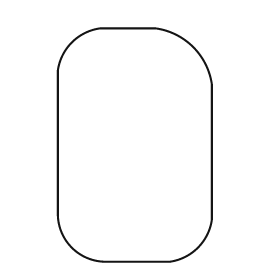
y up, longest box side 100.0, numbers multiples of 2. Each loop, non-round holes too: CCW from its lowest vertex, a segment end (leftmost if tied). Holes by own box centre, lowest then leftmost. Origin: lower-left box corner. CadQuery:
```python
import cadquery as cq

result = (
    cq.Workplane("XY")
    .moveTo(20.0, 0.0)
    .lineTo(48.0, 0.0)
    .threePointArc((60.0, 6.0), (66.0, 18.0))
    .lineTo(66.0, 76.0)
    .threePointArc((58.0, 92.0), (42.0, 100.0))
    .lineTo(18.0, 100.0)
    .threePointArc((6.0, 94.0), (0.0, 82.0))
    .lineTo(0.0, 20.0)
    .threePointArc((6.0, 6.0), (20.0, 0.0))
    .close()
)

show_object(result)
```